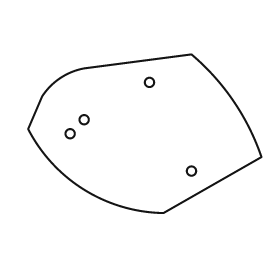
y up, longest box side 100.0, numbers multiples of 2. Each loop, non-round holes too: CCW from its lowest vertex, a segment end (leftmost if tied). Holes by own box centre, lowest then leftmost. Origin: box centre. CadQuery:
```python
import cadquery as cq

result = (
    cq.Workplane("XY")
    .moveTo(8.0, -34.0)
    .lineTo(50.0, -10.0)
    .threePointArc((38.0, 14.0), (20.0, 34.0))
    .lineTo(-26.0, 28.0)
    .threePointArc((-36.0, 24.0), (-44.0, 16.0))
    .lineTo(-50.0, 2.0)
    .threePointArc((-26.0, -24.0), (8.0, -34.0))
    .close()
    .moveTo(20.0, -16.0)
    .circle(2.0)
    .moveTo(-32.0, 0.0)
    .circle(2.0)
    .moveTo(-26.0, 6.0)
    .circle(2.0)
    .moveTo(2.0, 22.0)
    .circle(2.0)
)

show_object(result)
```